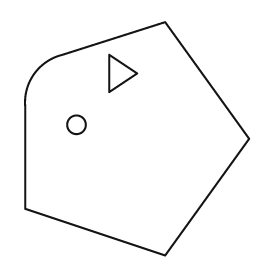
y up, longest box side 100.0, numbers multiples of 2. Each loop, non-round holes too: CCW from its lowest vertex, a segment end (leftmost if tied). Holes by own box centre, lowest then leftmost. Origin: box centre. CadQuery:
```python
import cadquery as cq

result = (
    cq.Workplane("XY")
    .moveTo(12.0, -50.0)
    .lineTo(48.0, 0.0)
    .lineTo(12.0, 50.0)
    .lineTo(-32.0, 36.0)
    .threePointArc((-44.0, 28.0), (-48.0, 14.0))
    .lineTo(-48.0, -30.0)
    .close()
    .moveTo(-26.0, 6.0)
    .circle(4.0)
    .moveTo(-12.0, 20.0)
    .lineTo(0.0, 28.0)
    .lineTo(-12.0, 36.0)
    .close()
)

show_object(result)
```